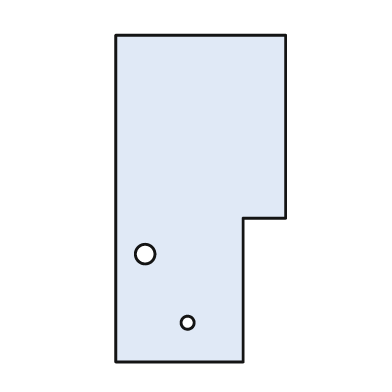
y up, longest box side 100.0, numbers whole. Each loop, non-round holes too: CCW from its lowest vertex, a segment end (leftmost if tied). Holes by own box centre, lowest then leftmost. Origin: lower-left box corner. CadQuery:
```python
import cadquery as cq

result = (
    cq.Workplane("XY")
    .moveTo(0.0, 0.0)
    .lineTo(39.0, 0.0)
    .lineTo(39.0, 44.0)
    .lineTo(52.0, 44.0)
    .lineTo(52.0, 100.0)
    .lineTo(0.0, 100.0)
    .close()
    .moveTo(22.0, 12.0)
    .circle(2.0)
    .moveTo(9.0, 33.0)
    .circle(3.0)
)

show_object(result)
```